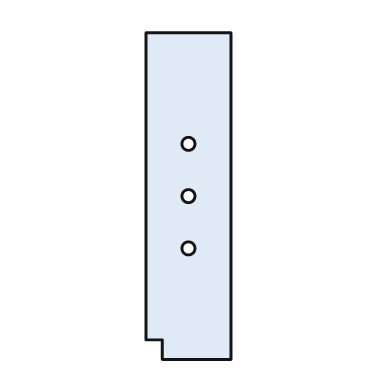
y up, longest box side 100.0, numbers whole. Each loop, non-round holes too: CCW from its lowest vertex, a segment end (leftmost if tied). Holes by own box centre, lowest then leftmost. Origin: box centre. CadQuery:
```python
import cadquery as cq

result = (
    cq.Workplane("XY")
    .moveTo(-8.0, -50.0)
    .lineTo(13.0, -50.0)
    .lineTo(13.0, 50.0)
    .lineTo(-13.0, 50.0)
    .lineTo(-13.0, -44.0)
    .lineTo(-8.0, -44.0)
    .close()
    .moveTo(0.0, -16.0)
    .circle(2.0)
    .moveTo(0.0, 0.0)
    .circle(2.0)
    .moveTo(0.0, 16.0)
    .circle(2.0)
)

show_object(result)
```